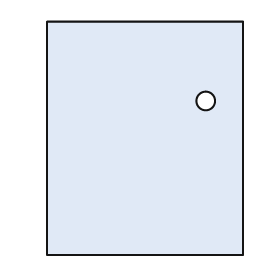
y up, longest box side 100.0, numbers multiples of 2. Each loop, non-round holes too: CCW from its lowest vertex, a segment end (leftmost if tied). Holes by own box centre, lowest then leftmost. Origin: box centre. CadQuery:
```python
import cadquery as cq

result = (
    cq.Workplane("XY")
    .moveTo(-42.0, -50.0)
    .lineTo(42.0, -50.0)
    .lineTo(42.0, 50.0)
    .lineTo(-42.0, 50.0)
    .close()
    .moveTo(26.0, 16.0)
    .circle(4.0)
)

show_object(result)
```